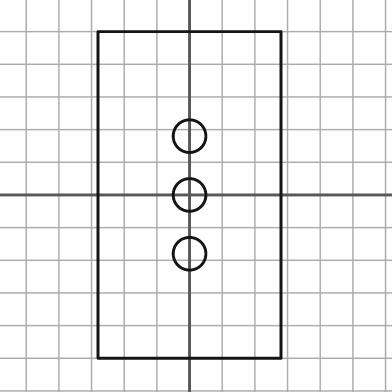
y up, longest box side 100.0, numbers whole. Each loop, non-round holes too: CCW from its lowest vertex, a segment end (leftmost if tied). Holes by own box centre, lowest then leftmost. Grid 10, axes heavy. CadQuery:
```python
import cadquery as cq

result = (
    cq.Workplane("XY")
    .moveTo(-28.0, -50.0)
    .lineTo(28.0, -50.0)
    .lineTo(28.0, 50.0)
    .lineTo(-28.0, 50.0)
    .close()
    .moveTo(0.0, -18.0)
    .circle(5.0)
    .moveTo(0.0, 0.0)
    .circle(5.0)
    .moveTo(0.0, 18.0)
    .circle(5.0)
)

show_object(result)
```